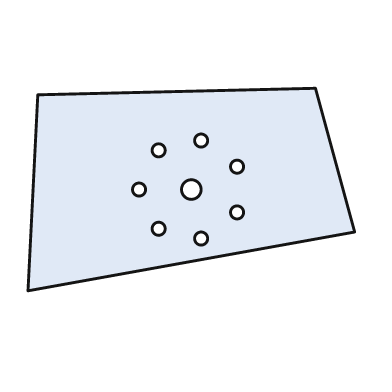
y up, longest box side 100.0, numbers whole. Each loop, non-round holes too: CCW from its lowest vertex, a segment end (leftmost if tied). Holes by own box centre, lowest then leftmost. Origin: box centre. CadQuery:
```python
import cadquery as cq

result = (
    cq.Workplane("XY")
    .moveTo(-50.0, -31.0)
    .lineTo(50.0, -13.0)
    .lineTo(38.0, 31.0)
    .lineTo(-47.0, 29.0)
    .close()
    .moveTo(3.0, -15.0)
    .circle(2.0)
    .moveTo(-10.0, -12.0)
    .circle(2.0)
    .moveTo(14.0, -7.0)
    .circle(2.0)
    .moveTo(-16.0, 0.0)
    .circle(2.0)
    .moveTo(0.0, 0.0)
    .circle(3.0)
    .moveTo(14.0, 7.0)
    .circle(2.0)
    .moveTo(-10.0, 12.0)
    .circle(2.0)
    .moveTo(3.0, 15.0)
    .circle(2.0)
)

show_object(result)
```